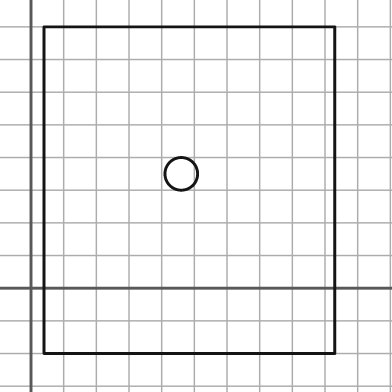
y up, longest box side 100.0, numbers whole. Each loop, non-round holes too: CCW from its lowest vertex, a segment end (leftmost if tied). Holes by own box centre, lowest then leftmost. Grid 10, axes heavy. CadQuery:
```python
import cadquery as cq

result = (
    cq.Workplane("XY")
    .moveTo(4.0, -20.0)
    .lineTo(93.0, -20.0)
    .lineTo(93.0, 80.0)
    .lineTo(4.0, 80.0)
    .close()
    .moveTo(46.0, 35.0)
    .circle(5.0)
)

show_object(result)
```